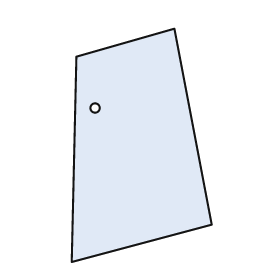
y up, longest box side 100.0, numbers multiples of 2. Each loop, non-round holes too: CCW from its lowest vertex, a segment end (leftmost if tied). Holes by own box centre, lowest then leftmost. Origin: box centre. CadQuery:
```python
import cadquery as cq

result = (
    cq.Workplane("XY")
    .moveTo(-30.0, -50.0)
    .lineTo(30.0, -34.0)
    .lineTo(14.0, 50.0)
    .lineTo(-28.0, 38.0)
    .close()
    .moveTo(-20.0, 16.0)
    .circle(2.0)
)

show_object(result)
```